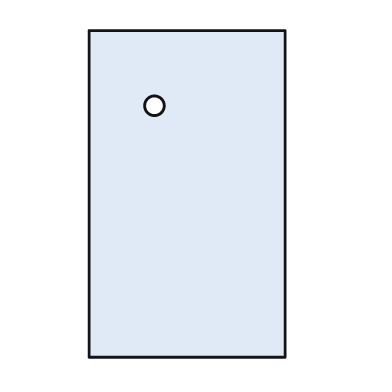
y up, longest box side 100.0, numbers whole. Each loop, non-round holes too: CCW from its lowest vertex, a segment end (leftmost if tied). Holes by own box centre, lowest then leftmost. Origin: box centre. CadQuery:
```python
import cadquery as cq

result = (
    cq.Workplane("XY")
    .moveTo(-30.0, -50.0)
    .lineTo(30.0, -50.0)
    .lineTo(30.0, 50.0)
    .lineTo(-30.0, 50.0)
    .close()
    .moveTo(-10.0, 27.0)
    .circle(3.0)
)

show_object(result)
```